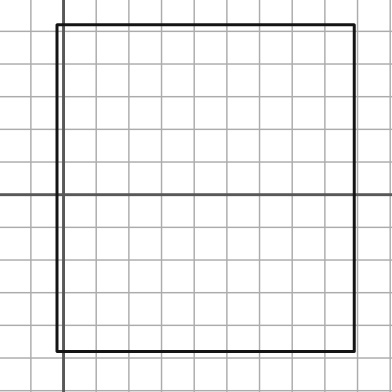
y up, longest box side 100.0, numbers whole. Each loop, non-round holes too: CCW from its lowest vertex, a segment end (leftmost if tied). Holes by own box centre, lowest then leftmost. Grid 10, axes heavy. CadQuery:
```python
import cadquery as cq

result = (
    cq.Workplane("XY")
    .moveTo(-2.0, -48.0)
    .lineTo(89.0, -48.0)
    .lineTo(89.0, 52.0)
    .lineTo(-2.0, 52.0)
    .close()
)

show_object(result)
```